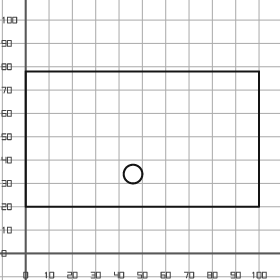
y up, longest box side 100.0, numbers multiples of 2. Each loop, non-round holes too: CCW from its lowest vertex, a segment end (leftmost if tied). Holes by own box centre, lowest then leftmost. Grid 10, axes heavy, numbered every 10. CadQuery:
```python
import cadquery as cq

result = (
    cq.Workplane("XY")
    .moveTo(0.0, 20.0)
    .lineTo(100.0, 20.0)
    .lineTo(100.0, 78.0)
    .lineTo(0.0, 78.0)
    .close()
    .moveTo(46.0, 34.0)
    .circle(4.0)
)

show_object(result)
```